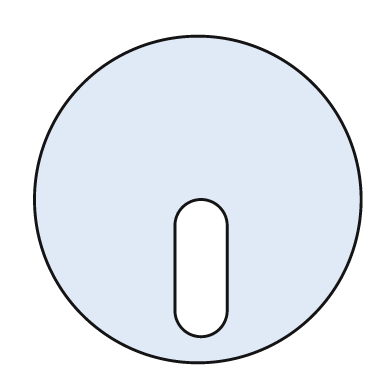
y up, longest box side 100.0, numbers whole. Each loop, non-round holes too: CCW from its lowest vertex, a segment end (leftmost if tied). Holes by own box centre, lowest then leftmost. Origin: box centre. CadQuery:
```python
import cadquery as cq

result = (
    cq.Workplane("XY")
    .moveTo(0.0, 0.0)
    .circle(50.0)
    .moveTo(-7.0, -34.0)
    .threePointArc((1.0, -42.0), (9.0, -34.0))
    .lineTo(9.0, -8.0)
    .threePointArc((1.0, 0.0), (-7.0, -8.0))
    .close()
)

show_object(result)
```